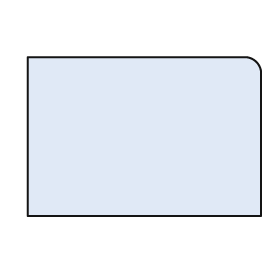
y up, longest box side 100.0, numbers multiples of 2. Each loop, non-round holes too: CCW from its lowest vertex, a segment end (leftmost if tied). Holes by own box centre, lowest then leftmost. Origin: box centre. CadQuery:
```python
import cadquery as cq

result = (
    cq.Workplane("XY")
    .moveTo(-50.0, -34.0)
    .lineTo(50.0, -34.0)
    .lineTo(50.0, 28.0)
    .threePointArc((48.0, 32.0), (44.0, 34.0))
    .lineTo(-50.0, 34.0)
    .close()
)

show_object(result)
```